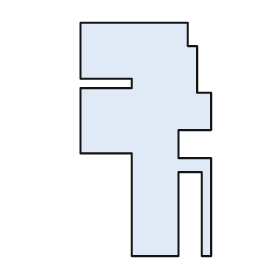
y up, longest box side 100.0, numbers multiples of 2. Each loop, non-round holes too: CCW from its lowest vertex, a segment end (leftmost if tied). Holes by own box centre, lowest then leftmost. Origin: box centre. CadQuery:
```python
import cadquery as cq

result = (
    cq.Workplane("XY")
    .moveTo(-6.0, -50.0)
    .lineTo(14.0, -50.0)
    .lineTo(14.0, -14.0)
    .lineTo(24.0, -14.0)
    .lineTo(24.0, -50.0)
    .lineTo(28.0, -50.0)
    .lineTo(28.0, -8.0)
    .lineTo(14.0, -8.0)
    .lineTo(14.0, 4.0)
    .lineTo(28.0, 4.0)
    .lineTo(28.0, 20.0)
    .lineTo(22.0, 20.0)
    .lineTo(22.0, 40.0)
    .lineTo(18.0, 40.0)
    .lineTo(18.0, 50.0)
    .lineTo(-28.0, 50.0)
    .lineTo(-28.0, 26.0)
    .lineTo(-6.0, 26.0)
    .lineTo(-6.0, 22.0)
    .lineTo(-28.0, 22.0)
    .lineTo(-28.0, -6.0)
    .lineTo(-6.0, -6.0)
    .close()
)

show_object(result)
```